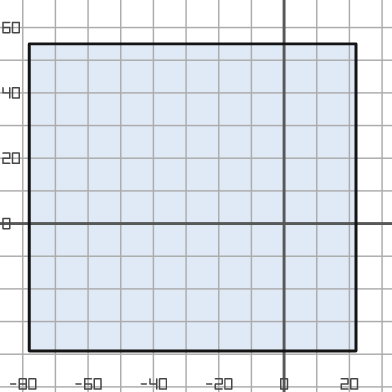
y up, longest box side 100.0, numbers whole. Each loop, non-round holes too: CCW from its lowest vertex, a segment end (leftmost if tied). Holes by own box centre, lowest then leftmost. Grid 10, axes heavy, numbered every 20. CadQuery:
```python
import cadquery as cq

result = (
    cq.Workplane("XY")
    .moveTo(-78.0, -39.0)
    .lineTo(22.0, -39.0)
    .lineTo(22.0, 55.0)
    .lineTo(-78.0, 55.0)
    .close()
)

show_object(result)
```